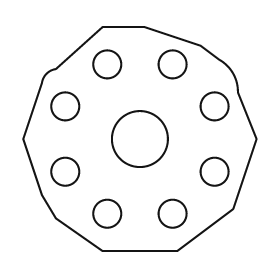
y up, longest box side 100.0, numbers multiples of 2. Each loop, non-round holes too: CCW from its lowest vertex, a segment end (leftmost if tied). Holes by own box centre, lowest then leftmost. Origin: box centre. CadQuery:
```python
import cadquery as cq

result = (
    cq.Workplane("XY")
    .moveTo(-16.0, -48.0)
    .lineTo(16.0, -48.0)
    .lineTo(40.0, -30.0)
    .lineTo(50.0, 0.0)
    .lineTo(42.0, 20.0)
    .threePointArc((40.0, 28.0), (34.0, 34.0))
    .lineTo(26.0, 40.0)
    .lineTo(2.0, 48.0)
    .lineTo(-16.0, 48.0)
    .lineTo(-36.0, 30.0)
    .threePointArc((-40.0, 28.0), (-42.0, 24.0))
    .lineTo(-50.0, 0.0)
    .lineTo(-42.0, -24.0)
    .lineTo(-36.0, -34.0)
    .close()
    .moveTo(-14.0, -32.0)
    .circle(6.0)
    .moveTo(14.0, -32.0)
    .circle(6.0)
    .moveTo(-32.0, -14.0)
    .circle(6.0)
    .moveTo(32.0, -14.0)
    .circle(6.0)
    .moveTo(0.0, 0.0)
    .circle(12.0)
    .moveTo(-32.0, 14.0)
    .circle(6.0)
    .moveTo(32.0, 14.0)
    .circle(6.0)
    .moveTo(-14.0, 32.0)
    .circle(6.0)
    .moveTo(14.0, 32.0)
    .circle(6.0)
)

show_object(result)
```